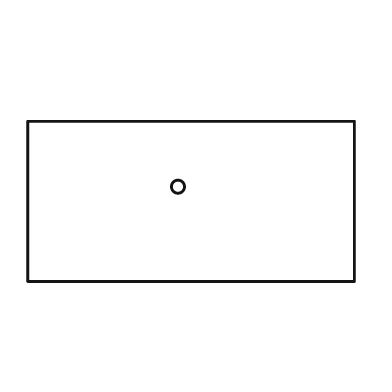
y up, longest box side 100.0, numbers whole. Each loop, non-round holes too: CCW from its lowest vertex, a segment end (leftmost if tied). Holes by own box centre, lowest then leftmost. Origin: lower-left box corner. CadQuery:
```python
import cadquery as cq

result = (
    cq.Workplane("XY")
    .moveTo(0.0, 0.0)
    .lineTo(100.0, 0.0)
    .lineTo(100.0, 49.0)
    .lineTo(0.0, 49.0)
    .close()
    .moveTo(46.0, 29.0)
    .circle(2.0)
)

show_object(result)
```